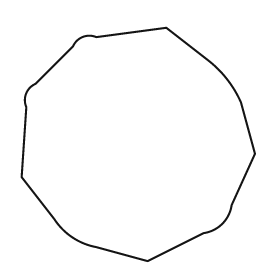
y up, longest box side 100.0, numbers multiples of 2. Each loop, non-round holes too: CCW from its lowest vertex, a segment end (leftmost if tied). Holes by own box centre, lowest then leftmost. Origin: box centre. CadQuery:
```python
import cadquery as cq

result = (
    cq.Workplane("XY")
    .moveTo(4.0, -50.0)
    .lineTo(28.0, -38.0)
    .threePointArc((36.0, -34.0), (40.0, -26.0))
    .lineTo(50.0, -4.0)
    .lineTo(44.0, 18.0)
    .threePointArc((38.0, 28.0), (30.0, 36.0))
    .lineTo(12.0, 50.0)
    .lineTo(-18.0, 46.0)
    .threePointArc((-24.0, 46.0), (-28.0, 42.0))
    .lineTo(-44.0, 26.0)
    .threePointArc((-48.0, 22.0), (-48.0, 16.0))
    .lineTo(-50.0, -14.0)
    .lineTo(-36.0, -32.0)
    .threePointArc((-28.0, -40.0), (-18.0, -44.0))
    .close()
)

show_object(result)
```